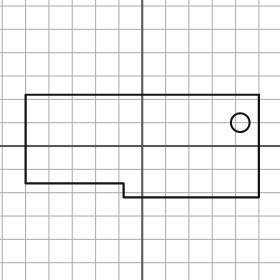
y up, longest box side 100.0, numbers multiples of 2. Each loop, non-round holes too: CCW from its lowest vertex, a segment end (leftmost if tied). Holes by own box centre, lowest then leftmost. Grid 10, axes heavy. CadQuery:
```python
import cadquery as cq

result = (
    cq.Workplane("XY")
    .moveTo(-8.0, -22.0)
    .lineTo(50.0, -22.0)
    .lineTo(50.0, 22.0)
    .lineTo(-50.0, 22.0)
    .lineTo(-50.0, -16.0)
    .lineTo(-8.0, -16.0)
    .close()
    .moveTo(42.0, 10.0)
    .circle(4.0)
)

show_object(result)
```